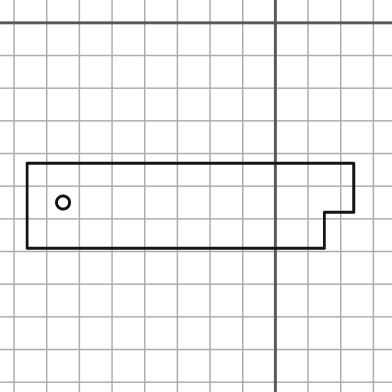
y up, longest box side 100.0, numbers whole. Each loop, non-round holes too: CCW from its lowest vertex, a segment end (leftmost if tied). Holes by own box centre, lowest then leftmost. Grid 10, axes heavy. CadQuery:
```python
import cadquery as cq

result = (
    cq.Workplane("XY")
    .moveTo(-76.0, -69.0)
    .lineTo(15.0, -69.0)
    .lineTo(15.0, -58.0)
    .lineTo(24.0, -58.0)
    .lineTo(24.0, -43.0)
    .lineTo(-76.0, -43.0)
    .close()
    .moveTo(-65.0, -55.0)
    .circle(2.0)
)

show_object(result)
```